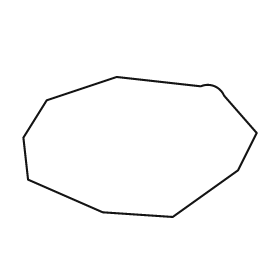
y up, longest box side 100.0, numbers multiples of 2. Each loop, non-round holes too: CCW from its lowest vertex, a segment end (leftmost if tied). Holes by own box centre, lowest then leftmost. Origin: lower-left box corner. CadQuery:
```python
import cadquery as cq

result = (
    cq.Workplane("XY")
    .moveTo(64.0, 0.0)
    .lineTo(92.0, 20.0)
    .lineTo(100.0, 36.0)
    .lineTo(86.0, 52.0)
    .threePointArc((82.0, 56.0), (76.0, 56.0))
    .lineTo(40.0, 60.0)
    .lineTo(10.0, 50.0)
    .lineTo(0.0, 34.0)
    .lineTo(2.0, 16.0)
    .lineTo(34.0, 2.0)
    .close()
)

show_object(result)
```